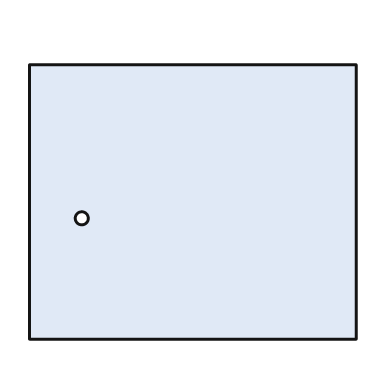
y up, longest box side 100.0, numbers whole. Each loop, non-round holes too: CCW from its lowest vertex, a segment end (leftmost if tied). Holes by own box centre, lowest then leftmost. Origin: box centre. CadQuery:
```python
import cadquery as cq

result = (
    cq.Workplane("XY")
    .moveTo(-50.0, -42.0)
    .lineTo(50.0, -42.0)
    .lineTo(50.0, 42.0)
    .lineTo(-50.0, 42.0)
    .close()
    .moveTo(-34.0, -5.0)
    .circle(2.0)
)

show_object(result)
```